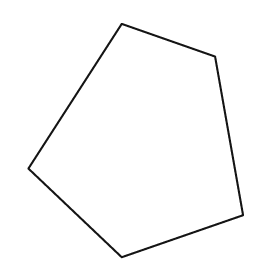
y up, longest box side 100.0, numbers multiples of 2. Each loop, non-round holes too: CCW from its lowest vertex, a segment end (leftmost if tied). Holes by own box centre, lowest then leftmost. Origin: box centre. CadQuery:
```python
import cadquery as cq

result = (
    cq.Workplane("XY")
    .moveTo(-6.0, -50.0)
    .lineTo(46.0, -32.0)
    .lineTo(34.0, 36.0)
    .lineTo(-6.0, 50.0)
    .lineTo(-46.0, -12.0)
    .close()
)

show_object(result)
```